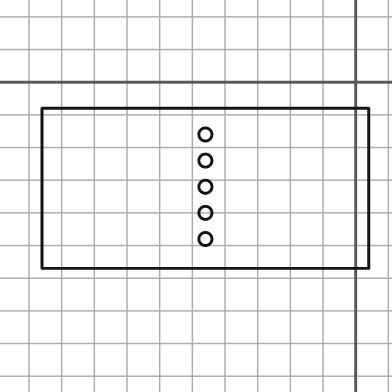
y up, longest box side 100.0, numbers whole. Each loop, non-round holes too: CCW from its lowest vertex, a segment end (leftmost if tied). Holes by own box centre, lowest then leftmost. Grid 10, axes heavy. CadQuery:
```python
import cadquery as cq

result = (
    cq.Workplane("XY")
    .moveTo(-96.0, -57.0)
    .lineTo(4.0, -57.0)
    .lineTo(4.0, -8.0)
    .lineTo(-96.0, -8.0)
    .close()
    .moveTo(-46.0, -48.0)
    .circle(2.0)
    .moveTo(-46.0, -40.0)
    .circle(2.0)
    .moveTo(-46.0, -32.0)
    .circle(2.0)
    .moveTo(-46.0, -24.0)
    .circle(2.0)
    .moveTo(-46.0, -16.0)
    .circle(2.0)
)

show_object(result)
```